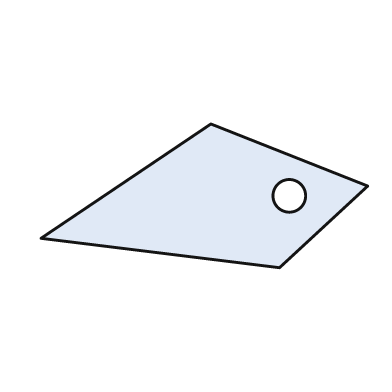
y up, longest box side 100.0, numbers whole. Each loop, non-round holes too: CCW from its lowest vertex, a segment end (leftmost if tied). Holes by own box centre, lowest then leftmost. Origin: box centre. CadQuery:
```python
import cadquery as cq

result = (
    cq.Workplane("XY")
    .moveTo(23.0, -22.0)
    .lineTo(50.0, 3.0)
    .lineTo(2.0, 22.0)
    .lineTo(-50.0, -13.0)
    .close()
    .moveTo(26.0, 0.0)
    .circle(5.0)
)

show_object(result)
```